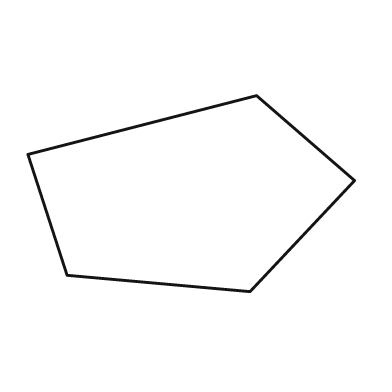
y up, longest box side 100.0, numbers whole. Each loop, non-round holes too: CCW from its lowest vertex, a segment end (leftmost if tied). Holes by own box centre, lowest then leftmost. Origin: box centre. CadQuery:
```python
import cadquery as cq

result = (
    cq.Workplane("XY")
    .moveTo(18.0, -30.0)
    .lineTo(50.0, 4.0)
    .lineTo(20.0, 30.0)
    .lineTo(-50.0, 12.0)
    .lineTo(-38.0, -25.0)
    .close()
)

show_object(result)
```